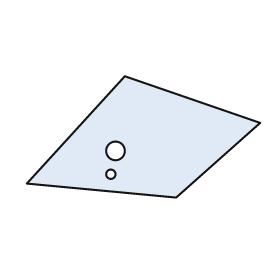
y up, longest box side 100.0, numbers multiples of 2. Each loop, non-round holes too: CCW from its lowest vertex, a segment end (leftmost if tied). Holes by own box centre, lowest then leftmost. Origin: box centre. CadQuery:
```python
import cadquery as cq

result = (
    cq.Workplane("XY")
    .moveTo(14.0, -26.0)
    .lineTo(50.0, 6.0)
    .lineTo(-8.0, 26.0)
    .lineTo(-50.0, -20.0)
    .close()
    .moveTo(-14.0, -16.0)
    .circle(2.0)
    .moveTo(-12.0, -6.0)
    .circle(4.0)
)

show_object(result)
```